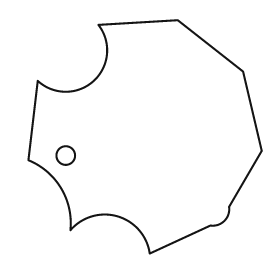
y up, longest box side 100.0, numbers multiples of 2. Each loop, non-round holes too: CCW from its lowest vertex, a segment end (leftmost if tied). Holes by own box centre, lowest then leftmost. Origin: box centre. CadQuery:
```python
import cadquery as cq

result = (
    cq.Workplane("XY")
    .moveTo(2.0, -50.0)
    .lineTo(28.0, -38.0)
    .threePointArc((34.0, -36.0), (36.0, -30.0))
    .lineTo(50.0, -6.0)
    .lineTo(42.0, 28.0)
    .lineTo(14.0, 50.0)
    .lineTo(-20.0, 48.0)
    .threePointArc((-22.0, 24.0), (-46.0, 24.0))
    .lineTo(-50.0, -10.0)
    .threePointArc((-36.0, -22.0), (-32.0, -40.0))
    .threePointArc((-12.0, -34.0), (2.0, -50.0))
    .close()
    .moveTo(-34.0, -8.0)
    .circle(4.0)
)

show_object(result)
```